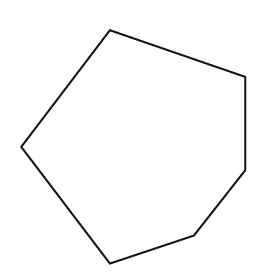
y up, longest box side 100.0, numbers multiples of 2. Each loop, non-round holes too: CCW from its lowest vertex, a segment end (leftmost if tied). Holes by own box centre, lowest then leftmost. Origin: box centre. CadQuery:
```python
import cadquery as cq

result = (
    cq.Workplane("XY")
    .moveTo(-10.0, -50.0)
    .lineTo(26.0, -38.0)
    .lineTo(48.0, -10.0)
    .lineTo(48.0, 30.0)
    .lineTo(-10.0, 50.0)
    .lineTo(-48.0, 0.0)
    .close()
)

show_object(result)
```